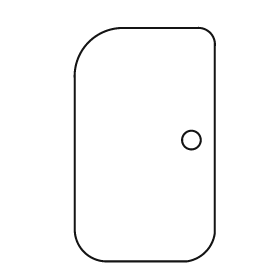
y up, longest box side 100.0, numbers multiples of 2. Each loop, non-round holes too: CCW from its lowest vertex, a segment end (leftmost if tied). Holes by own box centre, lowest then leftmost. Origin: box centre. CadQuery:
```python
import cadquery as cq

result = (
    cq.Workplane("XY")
    .moveTo(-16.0, -50.0)
    .lineTo(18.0, -50.0)
    .threePointArc((26.0, -46.0), (30.0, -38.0))
    .lineTo(30.0, 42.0)
    .threePointArc((28.0, 48.0), (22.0, 50.0))
    .lineTo(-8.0, 50.0)
    .threePointArc((-24.0, 44.0), (-30.0, 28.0))
    .lineTo(-30.0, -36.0)
    .threePointArc((-26.0, -46.0), (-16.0, -50.0))
    .close()
    .moveTo(20.0, 2.0)
    .circle(4.0)
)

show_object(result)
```